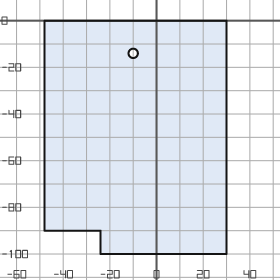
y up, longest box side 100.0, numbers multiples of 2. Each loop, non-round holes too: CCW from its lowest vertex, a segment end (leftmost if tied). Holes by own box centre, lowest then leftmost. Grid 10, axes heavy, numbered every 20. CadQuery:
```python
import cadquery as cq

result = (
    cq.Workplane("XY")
    .moveTo(-24.0, -100.0)
    .lineTo(30.0, -100.0)
    .lineTo(30.0, 0.0)
    .lineTo(-48.0, 0.0)
    .lineTo(-48.0, -90.0)
    .lineTo(-24.0, -90.0)
    .close()
    .moveTo(-10.0, -14.0)
    .circle(2.0)
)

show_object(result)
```